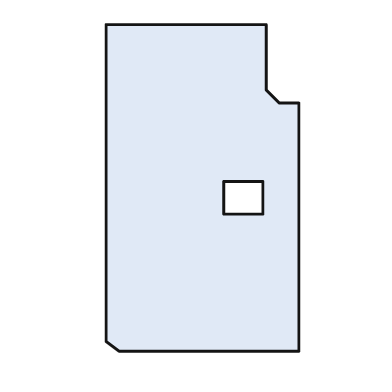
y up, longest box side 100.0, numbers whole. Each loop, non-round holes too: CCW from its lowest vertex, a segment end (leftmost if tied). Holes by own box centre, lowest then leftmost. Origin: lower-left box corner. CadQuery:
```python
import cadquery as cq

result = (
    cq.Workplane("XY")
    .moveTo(4.0, 0.0)
    .lineTo(59.0, 0.0)
    .lineTo(59.0, 76.0)
    .lineTo(53.0, 76.0)
    .lineTo(49.0, 80.0)
    .lineTo(49.0, 100.0)
    .lineTo(0.0, 100.0)
    .lineTo(0.0, 3.0)
    .close()
    .moveTo(36.0, 42.0)
    .lineTo(48.0, 42.0)
    .lineTo(48.0, 52.0)
    .lineTo(36.0, 52.0)
    .close()
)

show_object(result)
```